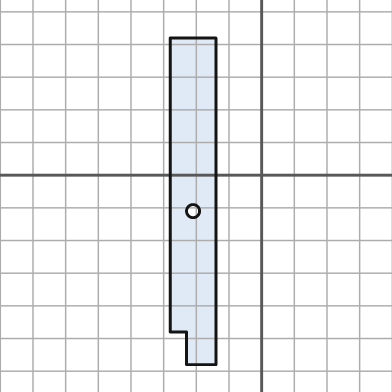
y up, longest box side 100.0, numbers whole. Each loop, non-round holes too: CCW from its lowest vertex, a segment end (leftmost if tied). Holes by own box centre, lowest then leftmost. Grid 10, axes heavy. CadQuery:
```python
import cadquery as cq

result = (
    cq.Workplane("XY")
    .moveTo(-23.0, -58.0)
    .lineTo(-14.0, -58.0)
    .lineTo(-14.0, 42.0)
    .lineTo(-28.0, 42.0)
    .lineTo(-28.0, -48.0)
    .lineTo(-23.0, -48.0)
    .close()
    .moveTo(-21.0, -11.0)
    .circle(2.0)
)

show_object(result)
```